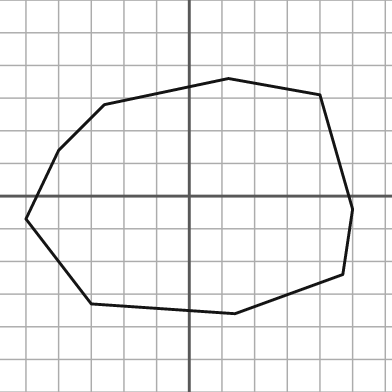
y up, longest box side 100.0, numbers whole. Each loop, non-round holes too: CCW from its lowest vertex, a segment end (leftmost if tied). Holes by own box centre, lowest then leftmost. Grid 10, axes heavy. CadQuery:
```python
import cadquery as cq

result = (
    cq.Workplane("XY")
    .moveTo(14.0, -36.0)
    .lineTo(47.0, -24.0)
    .lineTo(50.0, -4.0)
    .lineTo(40.0, 31.0)
    .lineTo(12.0, 36.0)
    .lineTo(-26.0, 28.0)
    .lineTo(-40.0, 14.0)
    .lineTo(-50.0, -7.0)
    .lineTo(-30.0, -33.0)
    .close()
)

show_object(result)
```